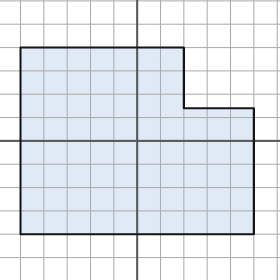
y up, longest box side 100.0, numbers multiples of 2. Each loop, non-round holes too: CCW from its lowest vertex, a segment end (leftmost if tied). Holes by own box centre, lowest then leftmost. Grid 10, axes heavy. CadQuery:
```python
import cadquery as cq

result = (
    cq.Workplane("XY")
    .moveTo(-50.0, -40.0)
    .lineTo(50.0, -40.0)
    .lineTo(50.0, 14.0)
    .lineTo(20.0, 14.0)
    .lineTo(20.0, 40.0)
    .lineTo(-50.0, 40.0)
    .close()
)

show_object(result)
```